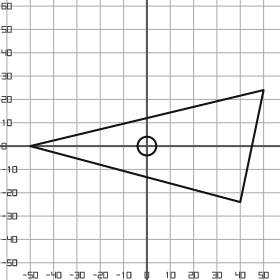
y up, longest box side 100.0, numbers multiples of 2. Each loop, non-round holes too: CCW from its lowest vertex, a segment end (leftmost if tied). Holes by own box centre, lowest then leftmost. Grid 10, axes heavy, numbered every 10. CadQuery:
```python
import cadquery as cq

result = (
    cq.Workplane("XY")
    .moveTo(40.0, -24.0)
    .lineTo(50.0, 24.0)
    .lineTo(-50.0, 0.0)
    .close()
    .moveTo(0.0, 0.0)
    .circle(4.0)
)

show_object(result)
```